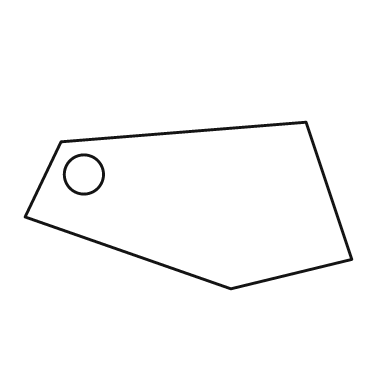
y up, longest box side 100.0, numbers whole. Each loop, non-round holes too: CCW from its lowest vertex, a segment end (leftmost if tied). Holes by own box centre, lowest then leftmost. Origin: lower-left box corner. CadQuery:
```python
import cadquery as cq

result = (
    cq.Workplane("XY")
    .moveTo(63.0, 0.0)
    .lineTo(100.0, 9.0)
    .lineTo(86.0, 51.0)
    .lineTo(11.0, 45.0)
    .lineTo(0.0, 22.0)
    .close()
    .moveTo(18.0, 35.0)
    .circle(6.0)
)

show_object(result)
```